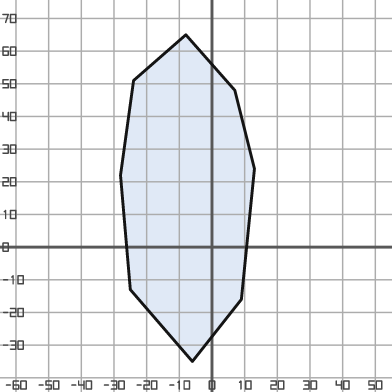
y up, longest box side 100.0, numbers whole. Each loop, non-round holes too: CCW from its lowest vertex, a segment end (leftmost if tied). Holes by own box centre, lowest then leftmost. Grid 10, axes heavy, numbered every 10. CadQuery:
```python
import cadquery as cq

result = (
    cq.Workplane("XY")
    .moveTo(-6.0, -35.0)
    .lineTo(9.0, -16.0)
    .lineTo(13.0, 24.0)
    .lineTo(7.0, 48.0)
    .lineTo(-8.0, 65.0)
    .lineTo(-24.0, 51.0)
    .lineTo(-28.0, 22.0)
    .lineTo(-25.0, -13.0)
    .close()
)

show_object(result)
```